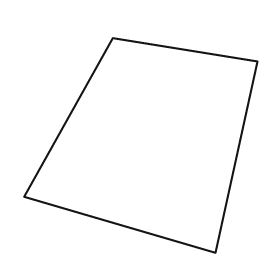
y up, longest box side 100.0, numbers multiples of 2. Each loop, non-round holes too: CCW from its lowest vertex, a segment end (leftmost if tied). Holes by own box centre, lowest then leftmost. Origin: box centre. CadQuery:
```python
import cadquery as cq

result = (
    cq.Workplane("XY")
    .moveTo(32.0, -46.0)
    .lineTo(50.0, 36.0)
    .lineTo(-12.0, 46.0)
    .lineTo(-50.0, -22.0)
    .close()
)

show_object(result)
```